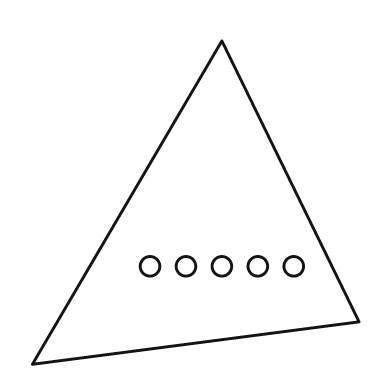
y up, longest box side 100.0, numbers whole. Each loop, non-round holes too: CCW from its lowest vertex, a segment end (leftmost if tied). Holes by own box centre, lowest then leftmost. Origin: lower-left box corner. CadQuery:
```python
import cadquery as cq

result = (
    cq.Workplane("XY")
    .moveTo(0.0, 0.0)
    .lineTo(100.0, 13.0)
    .lineTo(58.0, 99.0)
    .close()
    .moveTo(36.0, 30.0)
    .circle(3.0)
    .moveTo(47.0, 30.0)
    .circle(3.0)
    .moveTo(58.0, 30.0)
    .circle(3.0)
    .moveTo(69.0, 30.0)
    .circle(3.0)
    .moveTo(80.0, 30.0)
    .circle(3.0)
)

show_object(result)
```